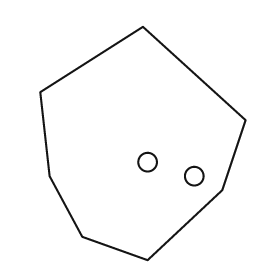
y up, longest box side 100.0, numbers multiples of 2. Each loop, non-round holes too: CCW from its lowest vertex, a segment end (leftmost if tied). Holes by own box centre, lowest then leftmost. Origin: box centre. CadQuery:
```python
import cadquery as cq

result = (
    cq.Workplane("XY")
    .moveTo(2.0, -50.0)
    .lineTo(34.0, -20.0)
    .lineTo(44.0, 10.0)
    .lineTo(0.0, 50.0)
    .lineTo(-44.0, 22.0)
    .lineTo(-40.0, -14.0)
    .lineTo(-26.0, -40.0)
    .close()
    .moveTo(22.0, -14.0)
    .circle(4.0)
    .moveTo(2.0, -8.0)
    .circle(4.0)
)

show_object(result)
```